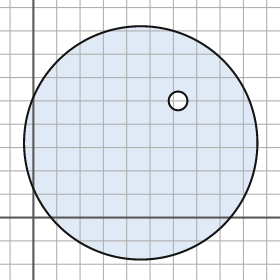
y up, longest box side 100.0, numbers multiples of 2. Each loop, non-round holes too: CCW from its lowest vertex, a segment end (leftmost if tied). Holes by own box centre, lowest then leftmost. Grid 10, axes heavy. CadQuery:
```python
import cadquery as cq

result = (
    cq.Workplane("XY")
    .moveTo(46.0, 32.0)
    .circle(50.0)
    .moveTo(62.0, 50.0)
    .circle(4.0)
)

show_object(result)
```